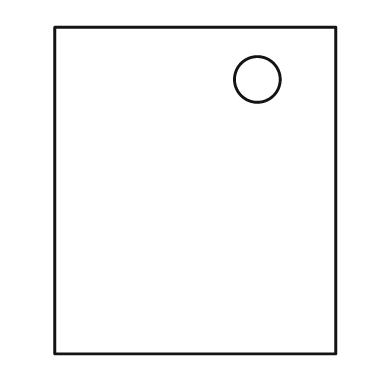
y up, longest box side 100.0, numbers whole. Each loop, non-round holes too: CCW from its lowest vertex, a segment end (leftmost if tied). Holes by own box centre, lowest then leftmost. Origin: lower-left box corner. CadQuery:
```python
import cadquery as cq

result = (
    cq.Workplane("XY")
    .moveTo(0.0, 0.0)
    .lineTo(86.0, 0.0)
    .lineTo(86.0, 100.0)
    .lineTo(0.0, 100.0)
    .close()
    .moveTo(62.0, 84.0)
    .circle(7.0)
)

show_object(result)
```